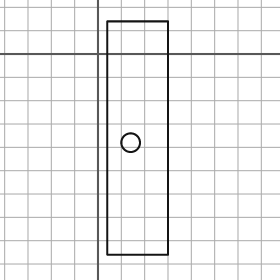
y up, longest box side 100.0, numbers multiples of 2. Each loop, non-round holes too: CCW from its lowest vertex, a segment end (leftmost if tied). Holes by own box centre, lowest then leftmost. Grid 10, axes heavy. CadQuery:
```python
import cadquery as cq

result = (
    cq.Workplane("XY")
    .moveTo(4.0, -86.0)
    .lineTo(30.0, -86.0)
    .lineTo(30.0, 14.0)
    .lineTo(4.0, 14.0)
    .close()
    .moveTo(14.0, -38.0)
    .circle(4.0)
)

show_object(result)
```